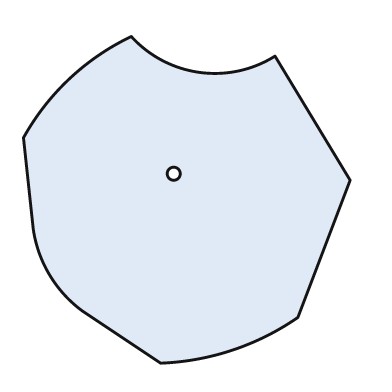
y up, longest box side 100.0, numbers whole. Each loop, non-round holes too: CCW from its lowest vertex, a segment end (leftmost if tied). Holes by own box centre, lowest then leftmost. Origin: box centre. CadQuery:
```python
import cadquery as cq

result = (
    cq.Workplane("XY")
    .moveTo(-8.0, -50.0)
    .threePointArc((14.0, -46.0), (34.0, -36.0))
    .lineTo(50.0, 6.0)
    .lineTo(27.0, 44.0)
    .threePointArc((4.0, 39.0), (-17.0, 50.0))
    .threePointArc((-36.0, 37.0), (-50.0, 19.0))
    .lineTo(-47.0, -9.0)
    .threePointArc((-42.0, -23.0), (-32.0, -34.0))
    .close()
    .moveTo(-4.0, 8.0)
    .circle(2.0)
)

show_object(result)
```